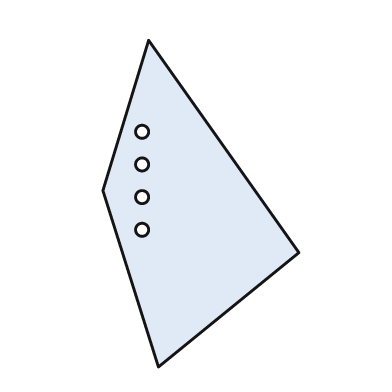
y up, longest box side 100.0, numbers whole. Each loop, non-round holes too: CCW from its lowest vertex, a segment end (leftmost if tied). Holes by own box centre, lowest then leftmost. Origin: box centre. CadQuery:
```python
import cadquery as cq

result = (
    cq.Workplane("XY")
    .moveTo(-13.0, -50.0)
    .lineTo(30.0, -15.0)
    .lineTo(-16.0, 50.0)
    .lineTo(-30.0, 4.0)
    .close()
    .moveTo(-18.0, -8.0)
    .circle(2.0)
    .moveTo(-18.0, 2.0)
    .circle(2.0)
    .moveTo(-18.0, 12.0)
    .circle(2.0)
    .moveTo(-18.0, 22.0)
    .circle(2.0)
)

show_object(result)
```